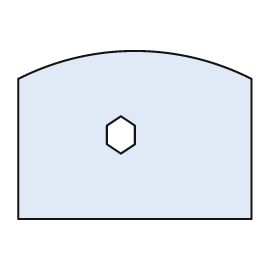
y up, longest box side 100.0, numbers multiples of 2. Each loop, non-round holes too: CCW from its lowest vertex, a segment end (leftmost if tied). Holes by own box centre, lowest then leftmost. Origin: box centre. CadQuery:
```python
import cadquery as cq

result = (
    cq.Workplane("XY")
    .moveTo(-50.0, -36.0)
    .lineTo(50.0, -36.0)
    .lineTo(50.0, 24.0)
    .threePointArc((0.0, 36.0), (-50.0, 24.0))
    .close()
    .moveTo(-6.0, -8.0)
    .lineTo(0.0, -4.0)
    .lineTo(0.0, 4.0)
    .lineTo(-6.0, 8.0)
    .lineTo(-12.0, 4.0)
    .lineTo(-12.0, -4.0)
    .close()
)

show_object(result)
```